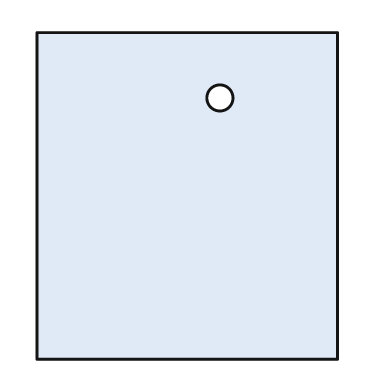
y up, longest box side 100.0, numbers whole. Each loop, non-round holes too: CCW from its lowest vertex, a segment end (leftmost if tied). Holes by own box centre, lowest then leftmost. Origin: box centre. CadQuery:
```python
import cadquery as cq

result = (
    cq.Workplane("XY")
    .moveTo(-46.0, -50.0)
    .lineTo(46.0, -50.0)
    .lineTo(46.0, 50.0)
    .lineTo(-46.0, 50.0)
    .close()
    .moveTo(10.0, 30.0)
    .circle(4.0)
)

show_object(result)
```